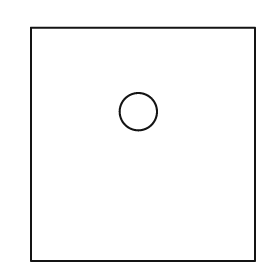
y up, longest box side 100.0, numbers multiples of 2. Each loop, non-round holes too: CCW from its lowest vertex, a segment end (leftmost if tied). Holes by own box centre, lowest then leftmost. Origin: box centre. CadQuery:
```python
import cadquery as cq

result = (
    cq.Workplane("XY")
    .moveTo(-48.0, -50.0)
    .lineTo(48.0, -50.0)
    .lineTo(48.0, 50.0)
    .lineTo(-48.0, 50.0)
    .close()
    .moveTo(-2.0, 14.0)
    .circle(8.0)
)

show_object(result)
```